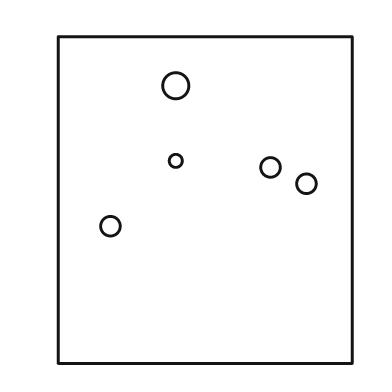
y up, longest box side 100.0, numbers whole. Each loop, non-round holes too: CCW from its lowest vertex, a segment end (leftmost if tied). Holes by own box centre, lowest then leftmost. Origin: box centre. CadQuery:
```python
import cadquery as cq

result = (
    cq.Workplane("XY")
    .moveTo(-45.0, -50.0)
    .lineTo(45.0, -50.0)
    .lineTo(45.0, 50.0)
    .lineTo(-45.0, 50.0)
    .close()
    .moveTo(-29.0, -8.0)
    .circle(3.0)
    .moveTo(31.0, 5.0)
    .circle(3.0)
    .moveTo(20.0, 10.0)
    .circle(3.0)
    .moveTo(-9.0, 12.0)
    .circle(2.0)
    .moveTo(-9.0, 35.0)
    .circle(4.0)
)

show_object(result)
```